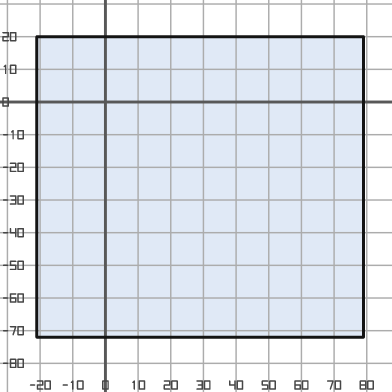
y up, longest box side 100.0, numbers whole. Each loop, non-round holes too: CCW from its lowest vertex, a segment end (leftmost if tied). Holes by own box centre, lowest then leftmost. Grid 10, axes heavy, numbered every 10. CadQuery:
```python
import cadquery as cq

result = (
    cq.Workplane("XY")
    .moveTo(-21.0, -72.0)
    .lineTo(79.0, -72.0)
    .lineTo(79.0, 20.0)
    .lineTo(-21.0, 20.0)
    .close()
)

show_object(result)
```